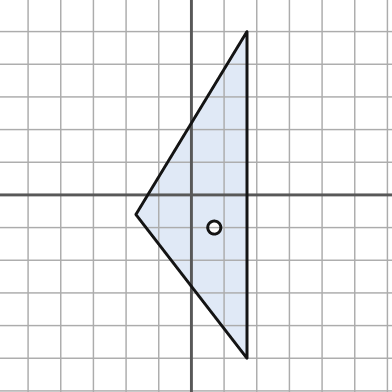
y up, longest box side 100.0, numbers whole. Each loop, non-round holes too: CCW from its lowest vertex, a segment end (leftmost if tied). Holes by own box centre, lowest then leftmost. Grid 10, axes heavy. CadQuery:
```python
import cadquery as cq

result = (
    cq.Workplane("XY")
    .moveTo(17.0, -50.0)
    .lineTo(17.0, 50.0)
    .lineTo(-17.0, -6.0)
    .close()
    .moveTo(7.0, -10.0)
    .circle(2.0)
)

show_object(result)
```